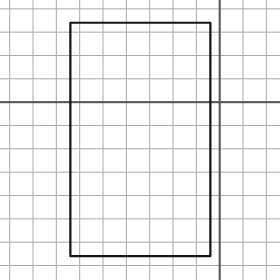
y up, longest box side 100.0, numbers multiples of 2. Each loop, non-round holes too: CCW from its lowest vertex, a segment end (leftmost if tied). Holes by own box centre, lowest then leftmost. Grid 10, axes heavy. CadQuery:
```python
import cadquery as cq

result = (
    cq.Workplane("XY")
    .moveTo(-64.0, -66.0)
    .lineTo(-4.0, -66.0)
    .lineTo(-4.0, 34.0)
    .lineTo(-64.0, 34.0)
    .close()
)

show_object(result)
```